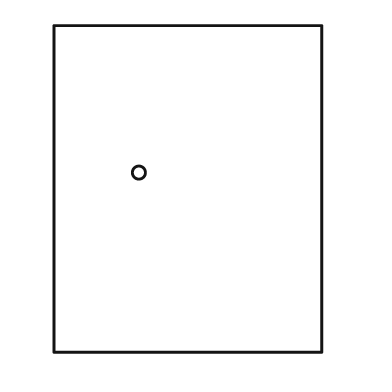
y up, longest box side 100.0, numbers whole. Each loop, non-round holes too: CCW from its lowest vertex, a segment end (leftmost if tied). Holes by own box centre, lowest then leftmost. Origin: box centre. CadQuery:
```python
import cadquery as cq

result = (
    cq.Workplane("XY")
    .moveTo(-41.0, -50.0)
    .lineTo(41.0, -50.0)
    .lineTo(41.0, 50.0)
    .lineTo(-41.0, 50.0)
    .close()
    .moveTo(-15.0, 5.0)
    .circle(2.0)
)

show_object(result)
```